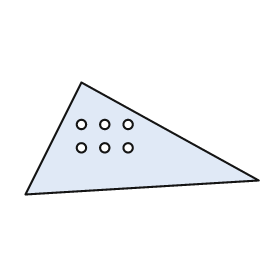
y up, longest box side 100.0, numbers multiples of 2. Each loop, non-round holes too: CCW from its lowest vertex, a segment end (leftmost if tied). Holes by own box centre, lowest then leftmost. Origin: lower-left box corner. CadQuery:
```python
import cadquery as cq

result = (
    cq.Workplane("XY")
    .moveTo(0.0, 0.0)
    .lineTo(100.0, 6.0)
    .lineTo(24.0, 48.0)
    .close()
    .moveTo(24.0, 20.0)
    .circle(2.0)
    .moveTo(34.0, 20.0)
    .circle(2.0)
    .moveTo(44.0, 20.0)
    .circle(2.0)
    .moveTo(24.0, 30.0)
    .circle(2.0)
    .moveTo(34.0, 30.0)
    .circle(2.0)
    .moveTo(44.0, 30.0)
    .circle(2.0)
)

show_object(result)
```